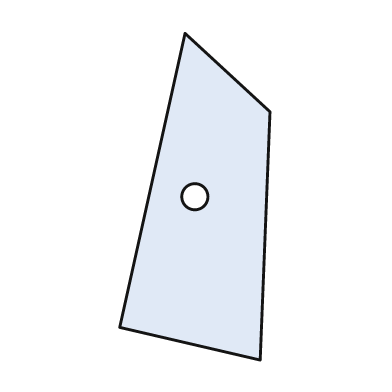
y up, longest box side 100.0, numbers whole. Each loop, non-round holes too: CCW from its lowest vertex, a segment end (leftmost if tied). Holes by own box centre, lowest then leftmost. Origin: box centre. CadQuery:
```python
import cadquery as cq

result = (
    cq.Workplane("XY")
    .moveTo(20.0, -50.0)
    .lineTo(23.0, 26.0)
    .lineTo(-3.0, 50.0)
    .lineTo(-23.0, -40.0)
    .close()
    .moveTo(0.0, 0.0)
    .circle(4.0)
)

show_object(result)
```